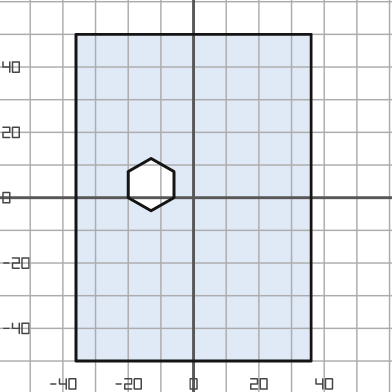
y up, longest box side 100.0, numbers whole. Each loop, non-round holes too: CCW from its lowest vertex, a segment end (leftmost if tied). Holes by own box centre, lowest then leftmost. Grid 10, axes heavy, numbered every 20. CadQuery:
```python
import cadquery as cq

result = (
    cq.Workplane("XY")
    .moveTo(-36.0, -50.0)
    .lineTo(36.0, -50.0)
    .lineTo(36.0, 50.0)
    .lineTo(-36.0, 50.0)
    .close()
    .moveTo(-13.0, -4.0)
    .lineTo(-6.0, 0.0)
    .lineTo(-6.0, 8.0)
    .lineTo(-13.0, 12.0)
    .lineTo(-20.0, 8.0)
    .lineTo(-20.0, 0.0)
    .close()
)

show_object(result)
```